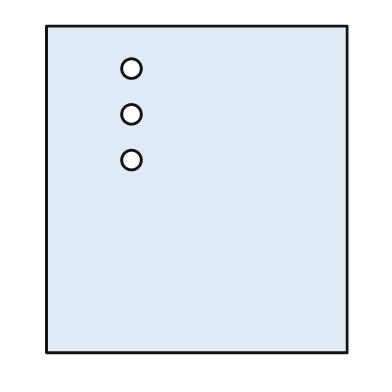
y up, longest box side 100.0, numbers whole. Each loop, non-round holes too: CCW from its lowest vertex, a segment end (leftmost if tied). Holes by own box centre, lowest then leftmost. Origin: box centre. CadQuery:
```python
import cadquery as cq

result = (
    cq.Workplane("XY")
    .moveTo(-46.0, -50.0)
    .lineTo(46.0, -50.0)
    .lineTo(46.0, 50.0)
    .lineTo(-46.0, 50.0)
    .close()
    .moveTo(-20.0, 9.0)
    .circle(3.0)
    .moveTo(-20.0, 23.0)
    .circle(3.0)
    .moveTo(-20.0, 37.0)
    .circle(3.0)
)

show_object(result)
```